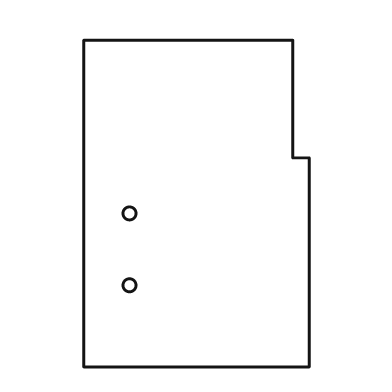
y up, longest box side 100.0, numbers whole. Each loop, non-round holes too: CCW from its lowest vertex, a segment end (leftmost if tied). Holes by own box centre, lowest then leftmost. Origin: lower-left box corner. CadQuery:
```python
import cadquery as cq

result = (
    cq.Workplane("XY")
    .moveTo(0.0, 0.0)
    .lineTo(69.0, 0.0)
    .lineTo(69.0, 64.0)
    .lineTo(64.0, 64.0)
    .lineTo(64.0, 100.0)
    .lineTo(0.0, 100.0)
    .close()
    .moveTo(14.0, 25.0)
    .circle(2.0)
    .moveTo(14.0, 47.0)
    .circle(2.0)
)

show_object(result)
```